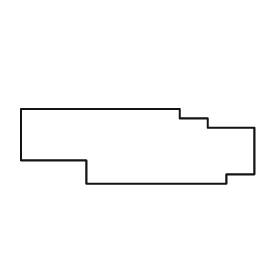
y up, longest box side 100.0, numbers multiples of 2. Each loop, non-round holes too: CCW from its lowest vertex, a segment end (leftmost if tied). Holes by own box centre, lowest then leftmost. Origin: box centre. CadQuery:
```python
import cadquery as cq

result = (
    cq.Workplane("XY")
    .moveTo(-22.0, -16.0)
    .lineTo(38.0, -16.0)
    .lineTo(38.0, -12.0)
    .lineTo(50.0, -12.0)
    .lineTo(50.0, 8.0)
    .lineTo(30.0, 8.0)
    .lineTo(30.0, 12.0)
    .lineTo(18.0, 12.0)
    .lineTo(18.0, 16.0)
    .lineTo(-50.0, 16.0)
    .lineTo(-50.0, -6.0)
    .lineTo(-22.0, -6.0)
    .close()
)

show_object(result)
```